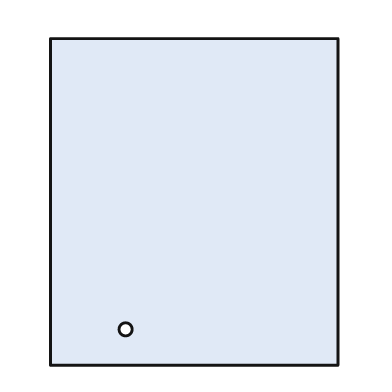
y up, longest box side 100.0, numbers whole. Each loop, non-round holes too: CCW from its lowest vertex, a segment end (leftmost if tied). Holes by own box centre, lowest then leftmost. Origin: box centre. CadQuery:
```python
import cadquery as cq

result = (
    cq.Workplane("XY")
    .moveTo(-44.0, -50.0)
    .lineTo(44.0, -50.0)
    .lineTo(44.0, 50.0)
    .lineTo(-44.0, 50.0)
    .close()
    .moveTo(-21.0, -39.0)
    .circle(2.0)
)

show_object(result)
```